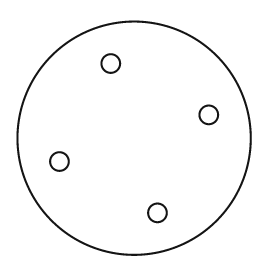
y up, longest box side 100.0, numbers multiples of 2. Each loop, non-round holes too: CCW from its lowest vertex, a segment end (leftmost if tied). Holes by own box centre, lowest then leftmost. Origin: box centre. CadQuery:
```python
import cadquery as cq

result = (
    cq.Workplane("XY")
    .moveTo(0.0, 0.0)
    .circle(50.0)
    .moveTo(10.0, -32.0)
    .circle(4.0)
    .moveTo(-32.0, -10.0)
    .circle(4.0)
    .moveTo(32.0, 10.0)
    .circle(4.0)
    .moveTo(-10.0, 32.0)
    .circle(4.0)
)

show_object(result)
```